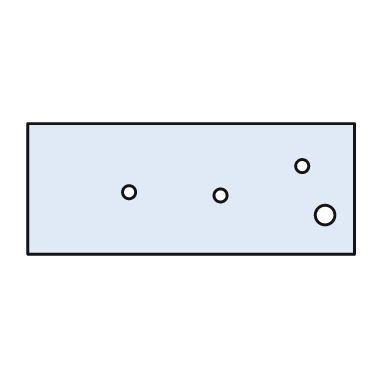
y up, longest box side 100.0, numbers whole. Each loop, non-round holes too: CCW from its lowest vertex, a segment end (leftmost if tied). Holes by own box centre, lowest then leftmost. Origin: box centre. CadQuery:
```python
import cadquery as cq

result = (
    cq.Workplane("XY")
    .moveTo(-50.0, -20.0)
    .lineTo(50.0, -20.0)
    .lineTo(50.0, 20.0)
    .lineTo(-50.0, 20.0)
    .close()
    .moveTo(41.0, -8.0)
    .circle(3.0)
    .moveTo(9.0, -2.0)
    .circle(2.0)
    .moveTo(-19.0, -1.0)
    .circle(2.0)
    .moveTo(34.0, 7.0)
    .circle(2.0)
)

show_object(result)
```